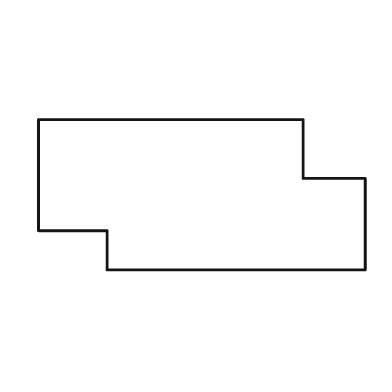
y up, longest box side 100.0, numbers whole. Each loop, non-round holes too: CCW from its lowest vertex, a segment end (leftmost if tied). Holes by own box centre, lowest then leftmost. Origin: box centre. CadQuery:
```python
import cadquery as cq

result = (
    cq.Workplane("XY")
    .moveTo(-29.0, -23.0)
    .lineTo(50.0, -23.0)
    .lineTo(50.0, 5.0)
    .lineTo(31.0, 5.0)
    .lineTo(31.0, 23.0)
    .lineTo(-50.0, 23.0)
    .lineTo(-50.0, -11.0)
    .lineTo(-29.0, -11.0)
    .close()
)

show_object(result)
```